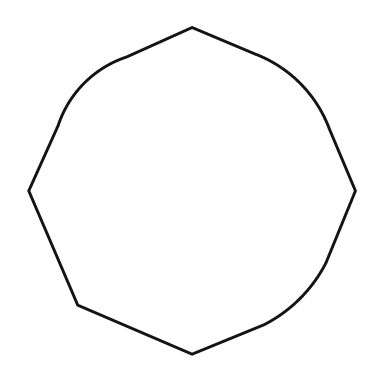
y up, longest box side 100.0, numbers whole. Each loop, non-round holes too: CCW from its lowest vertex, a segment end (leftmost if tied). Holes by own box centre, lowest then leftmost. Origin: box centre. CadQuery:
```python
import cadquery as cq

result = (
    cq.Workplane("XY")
    .moveTo(0.0, -50.0)
    .lineTo(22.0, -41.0)
    .threePointArc((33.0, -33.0), (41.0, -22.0))
    .lineTo(50.0, 0.0)
    .lineTo(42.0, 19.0)
    .threePointArc((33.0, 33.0), (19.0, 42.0))
    .lineTo(0.0, 50.0)
    .lineTo(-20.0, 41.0)
    .threePointArc((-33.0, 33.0), (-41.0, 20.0))
    .lineTo(-50.0, 0.0)
    .lineTo(-35.0, -35.0)
    .close()
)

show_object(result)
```